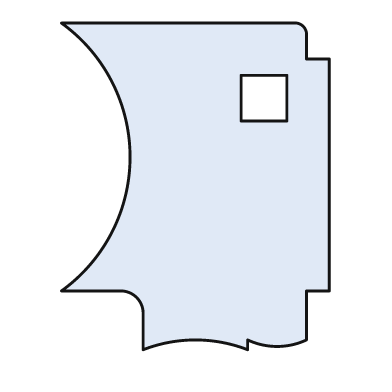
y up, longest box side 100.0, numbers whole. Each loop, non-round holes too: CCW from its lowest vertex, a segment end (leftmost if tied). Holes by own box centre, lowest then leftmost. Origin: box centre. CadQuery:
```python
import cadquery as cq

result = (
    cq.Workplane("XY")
    .moveTo(-16.0, -50.0)
    .threePointArc((0.0, -47.0), (16.0, -50.0))
    .lineTo(16.0, -47.0)
    .threePointArc((25.0, -49.0), (34.0, -47.0))
    .lineTo(34.0, -32.0)
    .lineTo(41.0, -32.0)
    .lineTo(41.0, 39.0)
    .lineTo(34.0, 39.0)
    .lineTo(34.0, 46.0)
    .threePointArc((33.0, 49.0), (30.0, 50.0))
    .lineTo(-41.0, 50.0)
    .threePointArc((-20.0, 9.0), (-41.0, -32.0))
    .lineTo(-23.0, -32.0)
    .threePointArc((-18.0, -34.0), (-16.0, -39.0))
    .close()
    .moveTo(14.0, 20.0)
    .lineTo(28.0, 20.0)
    .lineTo(28.0, 34.0)
    .lineTo(14.0, 34.0)
    .close()
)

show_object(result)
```